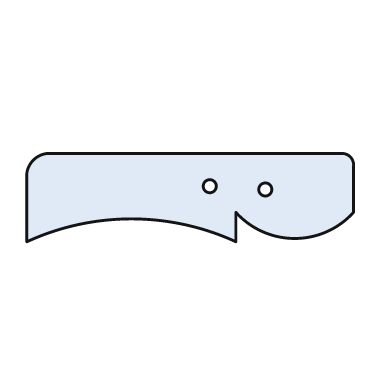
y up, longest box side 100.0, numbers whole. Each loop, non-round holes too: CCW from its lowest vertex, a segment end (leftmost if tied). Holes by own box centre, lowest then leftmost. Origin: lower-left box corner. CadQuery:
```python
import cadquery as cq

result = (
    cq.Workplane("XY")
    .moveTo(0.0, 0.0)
    .threePointArc((32.0, 7.0), (64.0, 0.0))
    .lineTo(64.0, 9.0)
    .threePointArc((82.0, 1.0), (100.0, 9.0))
    .lineTo(100.0, 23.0)
    .threePointArc((99.0, 26.0), (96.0, 27.0))
    .lineTo(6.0, 27.0)
    .threePointArc((2.0, 25.0), (0.0, 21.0))
    .close()
    .moveTo(73.0, 16.0)
    .circle(2.0)
    .moveTo(56.0, 17.0)
    .circle(2.0)
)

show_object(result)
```